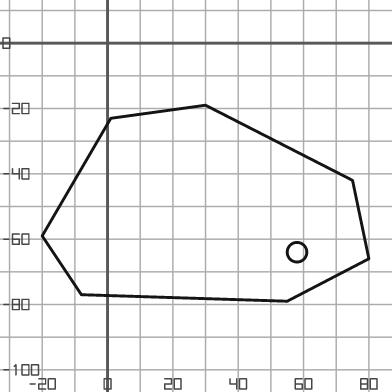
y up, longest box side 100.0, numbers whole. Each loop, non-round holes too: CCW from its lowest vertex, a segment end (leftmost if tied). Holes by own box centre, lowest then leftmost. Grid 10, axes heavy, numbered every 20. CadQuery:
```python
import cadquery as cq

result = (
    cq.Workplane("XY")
    .moveTo(55.0, -79.0)
    .lineTo(80.0, -66.0)
    .lineTo(75.0, -42.0)
    .lineTo(30.0, -19.0)
    .lineTo(1.0, -23.0)
    .lineTo(-20.0, -59.0)
    .lineTo(-8.0, -77.0)
    .close()
    .moveTo(58.0, -64.0)
    .circle(3.0)
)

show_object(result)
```